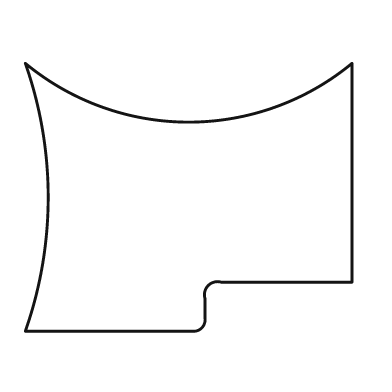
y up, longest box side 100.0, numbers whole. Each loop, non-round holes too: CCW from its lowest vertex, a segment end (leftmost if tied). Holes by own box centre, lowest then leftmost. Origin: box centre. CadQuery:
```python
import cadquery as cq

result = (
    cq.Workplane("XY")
    .moveTo(-50.0, -41.0)
    .lineTo(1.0, -41.0)
    .threePointArc((4.0, -40.0), (5.0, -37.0))
    .lineTo(5.0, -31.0)
    .threePointArc((6.0, -27.0), (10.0, -26.0))
    .lineTo(50.0, -26.0)
    .lineTo(50.0, 41.0)
    .threePointArc((0.0, 23.0), (-50.0, 41.0))
    .threePointArc((-43.0, 0.0), (-50.0, -41.0))
    .close()
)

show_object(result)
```